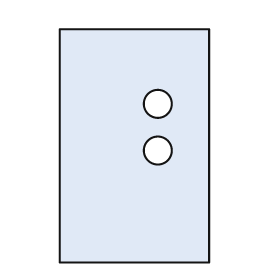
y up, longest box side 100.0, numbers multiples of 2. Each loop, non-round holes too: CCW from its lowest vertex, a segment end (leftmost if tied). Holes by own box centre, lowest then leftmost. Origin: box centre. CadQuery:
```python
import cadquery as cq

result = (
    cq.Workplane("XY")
    .moveTo(-32.0, -50.0)
    .lineTo(32.0, -50.0)
    .lineTo(32.0, 50.0)
    .lineTo(-32.0, 50.0)
    .close()
    .moveTo(10.0, -2.0)
    .circle(6.0)
    .moveTo(10.0, 18.0)
    .circle(6.0)
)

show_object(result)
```